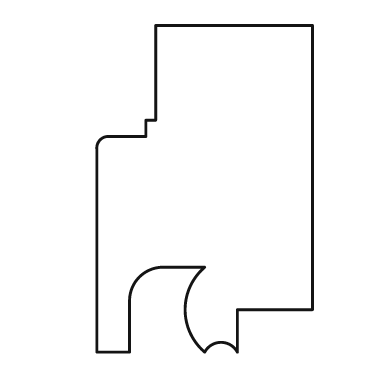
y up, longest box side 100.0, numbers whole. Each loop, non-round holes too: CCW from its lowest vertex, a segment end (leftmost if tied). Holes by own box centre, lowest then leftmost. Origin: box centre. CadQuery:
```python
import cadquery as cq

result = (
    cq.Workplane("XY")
    .moveTo(-33.0, -50.0)
    .lineTo(-23.0, -50.0)
    .lineTo(-23.0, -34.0)
    .threePointArc((-20.0, -27.0), (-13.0, -24.0))
    .lineTo(0.0, -24.0)
    .threePointArc((-6.0, -37.0), (0.0, -50.0))
    .threePointArc((5.0, -47.0), (10.0, -50.0))
    .lineTo(10.0, -37.0)
    .lineTo(33.0, -37.0)
    .lineTo(33.0, 50.0)
    .lineTo(-15.0, 50.0)
    .lineTo(-15.0, 21.0)
    .lineTo(-18.0, 21.0)
    .lineTo(-18.0, 16.0)
    .lineTo(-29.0, 16.0)
    .threePointArc((-32.0, 15.0), (-33.0, 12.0))
    .close()
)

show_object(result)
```